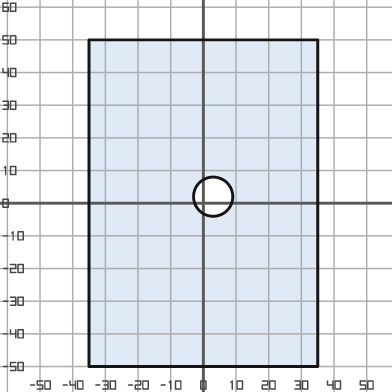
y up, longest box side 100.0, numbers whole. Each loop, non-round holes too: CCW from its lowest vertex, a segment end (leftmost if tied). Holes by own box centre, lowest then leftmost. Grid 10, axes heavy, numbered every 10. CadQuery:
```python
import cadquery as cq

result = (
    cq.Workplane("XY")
    .moveTo(-35.0, -50.0)
    .lineTo(35.0, -50.0)
    .lineTo(35.0, 50.0)
    .lineTo(-35.0, 50.0)
    .close()
    .moveTo(3.0, 2.0)
    .circle(6.0)
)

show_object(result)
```